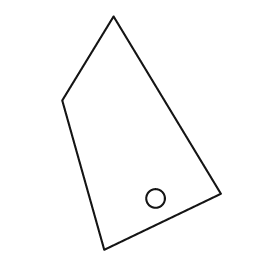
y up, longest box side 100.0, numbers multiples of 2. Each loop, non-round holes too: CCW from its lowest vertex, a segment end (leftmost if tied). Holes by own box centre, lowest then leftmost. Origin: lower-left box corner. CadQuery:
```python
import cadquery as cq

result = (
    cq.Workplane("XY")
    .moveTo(18.0, 0.0)
    .lineTo(68.0, 24.0)
    .lineTo(22.0, 100.0)
    .lineTo(0.0, 64.0)
    .close()
    .moveTo(40.0, 22.0)
    .circle(4.0)
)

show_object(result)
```